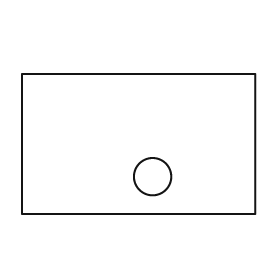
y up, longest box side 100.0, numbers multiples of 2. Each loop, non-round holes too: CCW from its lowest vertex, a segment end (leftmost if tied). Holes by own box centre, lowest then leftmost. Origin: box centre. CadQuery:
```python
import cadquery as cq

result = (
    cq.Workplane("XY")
    .moveTo(-50.0, -30.0)
    .lineTo(50.0, -30.0)
    .lineTo(50.0, 30.0)
    .lineTo(-50.0, 30.0)
    .close()
    .moveTo(6.0, -14.0)
    .circle(8.0)
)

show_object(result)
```